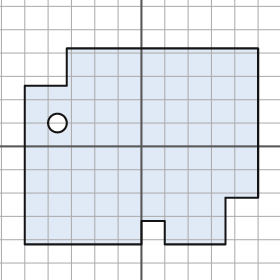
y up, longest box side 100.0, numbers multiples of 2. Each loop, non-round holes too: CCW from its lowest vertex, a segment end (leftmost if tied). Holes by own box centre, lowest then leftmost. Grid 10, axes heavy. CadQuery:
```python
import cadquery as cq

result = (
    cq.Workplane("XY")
    .moveTo(-50.0, -42.0)
    .lineTo(0.0, -42.0)
    .lineTo(0.0, -32.0)
    .lineTo(10.0, -32.0)
    .lineTo(10.0, -42.0)
    .lineTo(36.0, -42.0)
    .lineTo(36.0, -22.0)
    .lineTo(50.0, -22.0)
    .lineTo(50.0, 42.0)
    .lineTo(-32.0, 42.0)
    .lineTo(-32.0, 26.0)
    .lineTo(-50.0, 26.0)
    .close()
    .moveTo(-36.0, 10.0)
    .circle(4.0)
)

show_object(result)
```